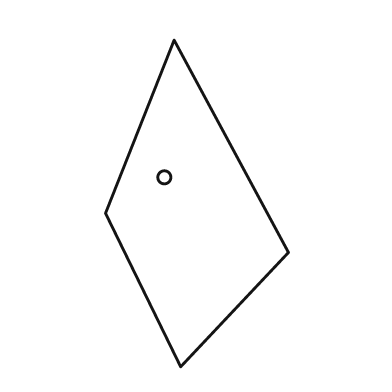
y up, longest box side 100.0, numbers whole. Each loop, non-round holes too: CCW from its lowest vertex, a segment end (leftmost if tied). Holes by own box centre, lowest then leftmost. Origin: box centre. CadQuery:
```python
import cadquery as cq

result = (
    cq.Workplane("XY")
    .moveTo(-5.0, -50.0)
    .lineTo(28.0, -15.0)
    .lineTo(-7.0, 50.0)
    .lineTo(-28.0, -3.0)
    .close()
    .moveTo(-10.0, 8.0)
    .circle(2.0)
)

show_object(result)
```